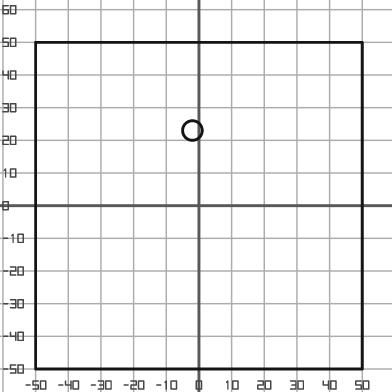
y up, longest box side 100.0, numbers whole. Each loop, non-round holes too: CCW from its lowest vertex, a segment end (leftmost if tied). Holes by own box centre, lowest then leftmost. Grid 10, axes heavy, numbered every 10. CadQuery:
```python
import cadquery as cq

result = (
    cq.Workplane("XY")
    .moveTo(-50.0, -50.0)
    .lineTo(50.0, -50.0)
    .lineTo(50.0, 50.0)
    .lineTo(-50.0, 50.0)
    .close()
    .moveTo(-2.0, 23.0)
    .circle(3.0)
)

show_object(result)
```